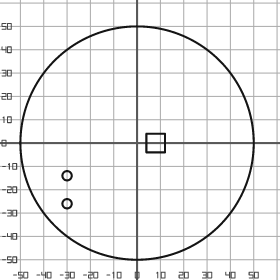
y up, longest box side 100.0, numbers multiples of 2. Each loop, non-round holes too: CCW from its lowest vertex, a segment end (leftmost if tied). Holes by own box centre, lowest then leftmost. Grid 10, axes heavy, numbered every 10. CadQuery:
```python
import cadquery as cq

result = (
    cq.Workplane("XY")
    .moveTo(0.0, 0.0)
    .circle(50.0)
    .moveTo(-30.0, -26.0)
    .circle(2.0)
    .moveTo(-30.0, -14.0)
    .circle(2.0)
    .moveTo(4.0, -4.0)
    .lineTo(12.0, -4.0)
    .lineTo(12.0, 4.0)
    .lineTo(4.0, 4.0)
    .close()
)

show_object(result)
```